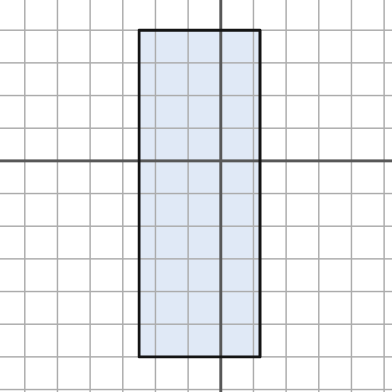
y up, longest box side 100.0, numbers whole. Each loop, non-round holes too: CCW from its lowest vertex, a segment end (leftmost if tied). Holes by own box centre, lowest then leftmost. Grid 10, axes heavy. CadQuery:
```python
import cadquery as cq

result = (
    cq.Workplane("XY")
    .moveTo(-25.0, -60.0)
    .lineTo(12.0, -60.0)
    .lineTo(12.0, 40.0)
    .lineTo(-25.0, 40.0)
    .close()
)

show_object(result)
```